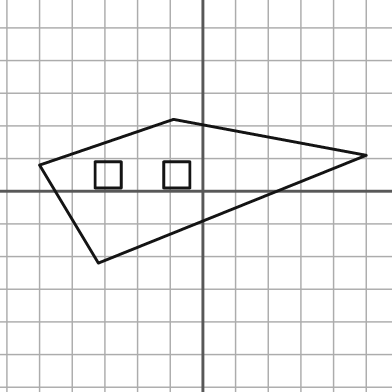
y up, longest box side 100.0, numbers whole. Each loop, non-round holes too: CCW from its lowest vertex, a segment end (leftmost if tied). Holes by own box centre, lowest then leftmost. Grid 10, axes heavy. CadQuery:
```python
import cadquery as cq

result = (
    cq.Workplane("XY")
    .moveTo(-32.0, -22.0)
    .lineTo(50.0, 11.0)
    .lineTo(-9.0, 22.0)
    .lineTo(-50.0, 8.0)
    .close()
    .moveTo(-33.0, 1.0)
    .lineTo(-25.0, 1.0)
    .lineTo(-25.0, 9.0)
    .lineTo(-33.0, 9.0)
    .close()
    .moveTo(-12.0, 1.0)
    .lineTo(-4.0, 1.0)
    .lineTo(-4.0, 9.0)
    .lineTo(-12.0, 9.0)
    .close()
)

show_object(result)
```